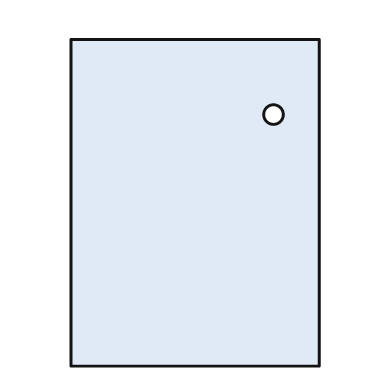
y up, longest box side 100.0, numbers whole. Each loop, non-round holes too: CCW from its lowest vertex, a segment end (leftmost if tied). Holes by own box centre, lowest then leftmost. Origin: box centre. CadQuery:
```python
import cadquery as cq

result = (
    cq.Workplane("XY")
    .moveTo(-38.0, -50.0)
    .lineTo(38.0, -50.0)
    .lineTo(38.0, 50.0)
    .lineTo(-38.0, 50.0)
    .close()
    .moveTo(24.0, 27.0)
    .circle(3.0)
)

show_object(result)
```